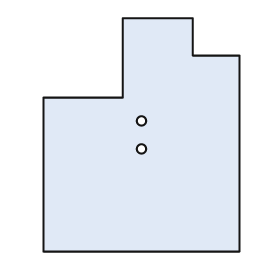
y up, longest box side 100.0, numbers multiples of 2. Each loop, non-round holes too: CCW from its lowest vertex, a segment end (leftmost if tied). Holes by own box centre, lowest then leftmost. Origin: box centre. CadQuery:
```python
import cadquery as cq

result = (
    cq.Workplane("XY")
    .moveTo(-42.0, -50.0)
    .lineTo(42.0, -50.0)
    .lineTo(42.0, 34.0)
    .lineTo(22.0, 34.0)
    .lineTo(22.0, 50.0)
    .lineTo(-8.0, 50.0)
    .lineTo(-8.0, 16.0)
    .lineTo(-42.0, 16.0)
    .close()
    .moveTo(0.0, -6.0)
    .circle(2.0)
    .moveTo(0.0, 6.0)
    .circle(2.0)
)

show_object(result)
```